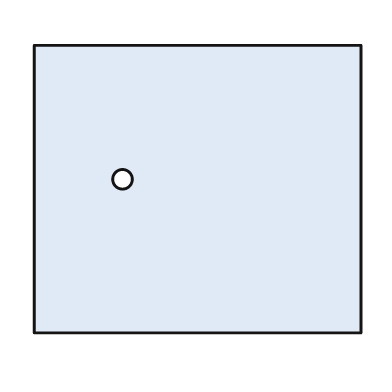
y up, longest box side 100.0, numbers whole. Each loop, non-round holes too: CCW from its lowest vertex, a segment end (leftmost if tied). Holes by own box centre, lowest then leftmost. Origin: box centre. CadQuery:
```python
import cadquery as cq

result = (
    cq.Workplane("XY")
    .moveTo(-50.0, -44.0)
    .lineTo(50.0, -44.0)
    .lineTo(50.0, 44.0)
    .lineTo(-50.0, 44.0)
    .close()
    .moveTo(-23.0, 3.0)
    .circle(3.0)
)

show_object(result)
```